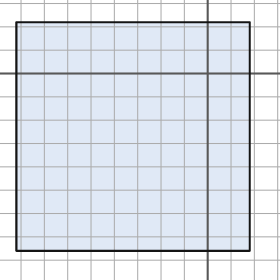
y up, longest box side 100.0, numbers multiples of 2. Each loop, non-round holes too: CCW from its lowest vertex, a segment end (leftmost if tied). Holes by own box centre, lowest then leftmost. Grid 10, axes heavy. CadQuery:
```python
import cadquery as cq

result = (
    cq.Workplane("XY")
    .moveTo(-82.0, -76.0)
    .lineTo(18.0, -76.0)
    .lineTo(18.0, 22.0)
    .lineTo(-82.0, 22.0)
    .close()
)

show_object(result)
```